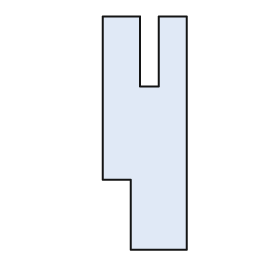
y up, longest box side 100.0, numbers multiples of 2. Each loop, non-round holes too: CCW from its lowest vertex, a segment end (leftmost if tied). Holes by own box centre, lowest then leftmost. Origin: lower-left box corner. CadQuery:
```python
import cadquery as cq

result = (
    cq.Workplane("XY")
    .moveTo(12.0, 0.0)
    .lineTo(36.0, 0.0)
    .lineTo(36.0, 100.0)
    .lineTo(24.0, 100.0)
    .lineTo(24.0, 70.0)
    .lineTo(16.0, 70.0)
    .lineTo(16.0, 100.0)
    .lineTo(0.0, 100.0)
    .lineTo(0.0, 30.0)
    .lineTo(12.0, 30.0)
    .close()
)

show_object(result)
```